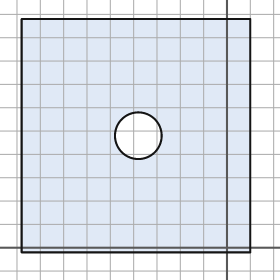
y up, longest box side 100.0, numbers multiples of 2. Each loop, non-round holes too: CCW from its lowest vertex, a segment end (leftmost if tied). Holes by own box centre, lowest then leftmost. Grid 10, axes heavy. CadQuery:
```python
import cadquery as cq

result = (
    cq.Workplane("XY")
    .moveTo(-88.0, -2.0)
    .lineTo(10.0, -2.0)
    .lineTo(10.0, 98.0)
    .lineTo(-88.0, 98.0)
    .close()
    .moveTo(-38.0, 48.0)
    .circle(10.0)
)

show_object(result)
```